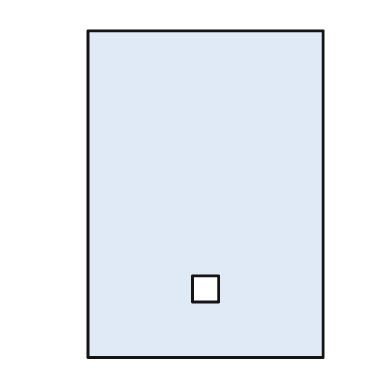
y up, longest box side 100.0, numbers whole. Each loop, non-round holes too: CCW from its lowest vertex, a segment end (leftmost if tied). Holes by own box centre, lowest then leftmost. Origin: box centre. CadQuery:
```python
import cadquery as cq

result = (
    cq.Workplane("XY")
    .moveTo(-36.0, -50.0)
    .lineTo(36.0, -50.0)
    .lineTo(36.0, 50.0)
    .lineTo(-36.0, 50.0)
    .close()
    .moveTo(-4.0, -33.0)
    .lineTo(4.0, -33.0)
    .lineTo(4.0, -25.0)
    .lineTo(-4.0, -25.0)
    .close()
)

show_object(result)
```